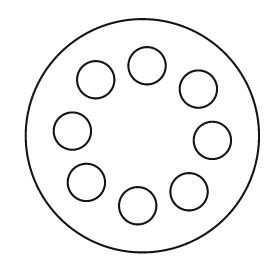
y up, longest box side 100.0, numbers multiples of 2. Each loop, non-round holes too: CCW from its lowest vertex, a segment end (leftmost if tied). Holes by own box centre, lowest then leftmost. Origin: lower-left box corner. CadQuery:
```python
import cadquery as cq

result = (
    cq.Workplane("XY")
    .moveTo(50.0, 50.0)
    .circle(50.0)
    .moveTo(48.0, 20.0)
    .circle(8.0)
    .moveTo(70.0, 26.0)
    .circle(8.0)
    .moveTo(26.0, 30.0)
    .circle(8.0)
    .moveTo(80.0, 48.0)
    .circle(8.0)
    .moveTo(20.0, 52.0)
    .circle(8.0)
    .moveTo(74.0, 70.0)
    .circle(8.0)
    .moveTo(30.0, 74.0)
    .circle(8.0)
    .moveTo(52.0, 80.0)
    .circle(8.0)
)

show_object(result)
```